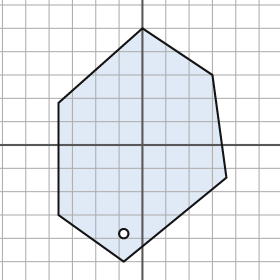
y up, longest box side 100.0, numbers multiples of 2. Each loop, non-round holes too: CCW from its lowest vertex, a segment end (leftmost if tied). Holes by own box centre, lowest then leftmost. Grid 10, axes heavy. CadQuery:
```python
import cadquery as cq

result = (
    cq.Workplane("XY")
    .moveTo(-8.0, -50.0)
    .lineTo(36.0, -14.0)
    .lineTo(30.0, 30.0)
    .lineTo(0.0, 50.0)
    .lineTo(-36.0, 18.0)
    .lineTo(-36.0, -30.0)
    .close()
    .moveTo(-8.0, -38.0)
    .circle(2.0)
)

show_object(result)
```